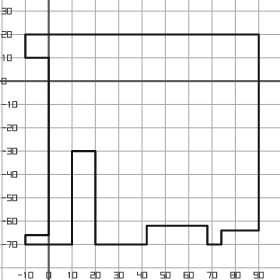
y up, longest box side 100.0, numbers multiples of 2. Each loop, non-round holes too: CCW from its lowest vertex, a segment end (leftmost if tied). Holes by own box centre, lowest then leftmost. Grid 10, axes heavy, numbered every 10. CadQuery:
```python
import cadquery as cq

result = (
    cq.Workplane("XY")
    .moveTo(-10.0, -70.0)
    .lineTo(10.0, -70.0)
    .lineTo(10.0, -30.0)
    .lineTo(20.0, -30.0)
    .lineTo(20.0, -70.0)
    .lineTo(42.0, -70.0)
    .lineTo(42.0, -62.0)
    .lineTo(68.0, -62.0)
    .lineTo(68.0, -70.0)
    .lineTo(74.0, -70.0)
    .lineTo(74.0, -64.0)
    .lineTo(90.0, -64.0)
    .lineTo(90.0, 20.0)
    .lineTo(-10.0, 20.0)
    .lineTo(-10.0, 10.0)
    .lineTo(0.0, 10.0)
    .lineTo(0.0, -66.0)
    .lineTo(-10.0, -66.0)
    .close()
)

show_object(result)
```